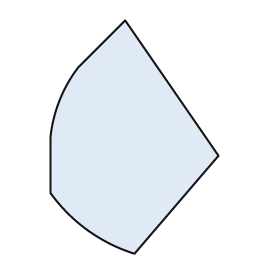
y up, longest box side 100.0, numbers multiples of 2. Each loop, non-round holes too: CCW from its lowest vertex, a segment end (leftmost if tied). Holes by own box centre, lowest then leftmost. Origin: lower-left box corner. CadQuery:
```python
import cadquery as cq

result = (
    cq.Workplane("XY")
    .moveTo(36.0, 0.0)
    .lineTo(72.0, 42.0)
    .lineTo(32.0, 100.0)
    .lineTo(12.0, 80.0)
    .threePointArc((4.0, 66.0), (0.0, 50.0))
    .lineTo(0.0, 26.0)
    .threePointArc((16.0, 10.0), (36.0, 0.0))
    .close()
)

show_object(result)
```